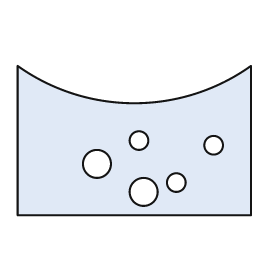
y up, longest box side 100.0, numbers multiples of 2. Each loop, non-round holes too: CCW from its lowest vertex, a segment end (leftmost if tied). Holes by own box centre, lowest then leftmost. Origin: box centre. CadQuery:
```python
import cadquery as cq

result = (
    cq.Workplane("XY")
    .moveTo(-50.0, -32.0)
    .lineTo(50.0, -32.0)
    .lineTo(50.0, 32.0)
    .threePointArc((0.0, 16.0), (-50.0, 32.0))
    .close()
    .moveTo(4.0, -22.0)
    .circle(6.0)
    .moveTo(18.0, -18.0)
    .circle(4.0)
    .moveTo(-16.0, -10.0)
    .circle(6.0)
    .moveTo(34.0, -2.0)
    .circle(4.0)
    .moveTo(2.0, 0.0)
    .circle(4.0)
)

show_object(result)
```